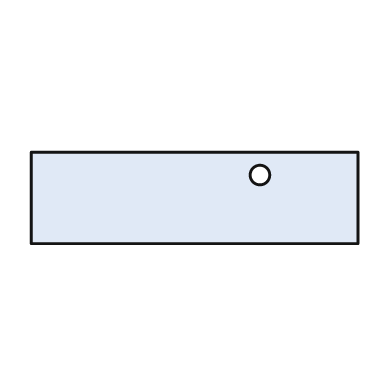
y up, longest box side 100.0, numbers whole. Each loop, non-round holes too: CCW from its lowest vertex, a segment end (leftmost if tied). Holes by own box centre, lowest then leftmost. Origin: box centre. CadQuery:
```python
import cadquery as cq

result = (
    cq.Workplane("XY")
    .moveTo(-50.0, -14.0)
    .lineTo(50.0, -14.0)
    .lineTo(50.0, 14.0)
    .lineTo(-50.0, 14.0)
    .close()
    .moveTo(20.0, 7.0)
    .circle(3.0)
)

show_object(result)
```